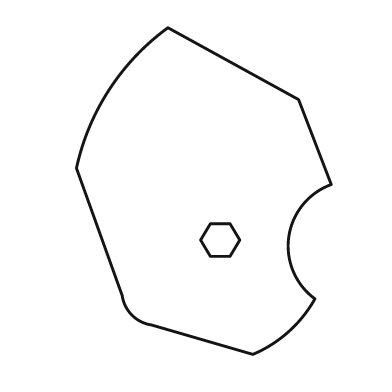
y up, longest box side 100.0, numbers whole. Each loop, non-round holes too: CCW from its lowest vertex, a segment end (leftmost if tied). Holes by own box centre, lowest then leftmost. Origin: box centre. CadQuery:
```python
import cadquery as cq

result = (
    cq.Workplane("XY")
    .moveTo(15.0, -50.0)
    .threePointArc((26.0, -43.0), (34.0, -33.0))
    .threePointArc((26.0, -14.0), (39.0, 2.0))
    .lineTo(29.0, 28.0)
    .lineTo(-11.0, 50.0)
    .threePointArc((-29.0, 31.0), (-39.0, 7.0))
    .lineTo(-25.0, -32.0)
    .threePointArc((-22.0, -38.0), (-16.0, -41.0))
    .close()
    .moveTo(2.0, -20.0)
    .lineTo(8.0, -20.0)
    .lineTo(11.0, -15.0)
    .lineTo(8.0, -10.0)
    .lineTo(2.0, -10.0)
    .lineTo(-1.0, -15.0)
    .close()
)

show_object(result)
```